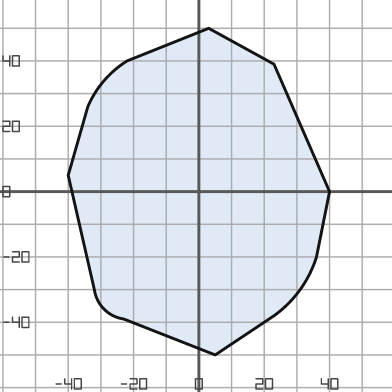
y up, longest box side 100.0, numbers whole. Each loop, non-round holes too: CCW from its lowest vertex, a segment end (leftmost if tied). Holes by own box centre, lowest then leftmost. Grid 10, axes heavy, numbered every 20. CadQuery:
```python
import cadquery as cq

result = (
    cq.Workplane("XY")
    .moveTo(5.0, -50.0)
    .lineTo(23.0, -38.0)
    .threePointArc((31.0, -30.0), (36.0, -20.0))
    .lineTo(40.0, 0.0)
    .lineTo(23.0, 39.0)
    .lineTo(3.0, 50.0)
    .lineTo(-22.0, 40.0)
    .threePointArc((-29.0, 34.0), (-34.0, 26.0))
    .lineTo(-40.0, 5.0)
    .lineTo(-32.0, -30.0)
    .threePointArc((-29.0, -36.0), (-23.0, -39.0))
    .close()
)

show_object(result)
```